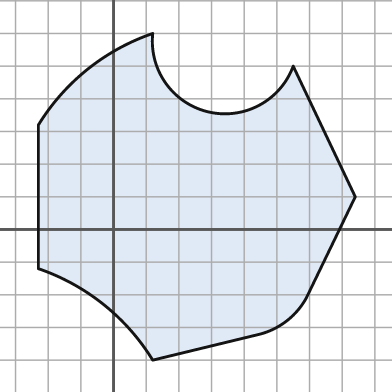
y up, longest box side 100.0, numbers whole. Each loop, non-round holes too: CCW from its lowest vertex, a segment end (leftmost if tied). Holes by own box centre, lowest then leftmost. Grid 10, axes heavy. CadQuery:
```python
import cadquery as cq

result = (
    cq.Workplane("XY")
    .moveTo(12.0, -40.0)
    .lineTo(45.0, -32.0)
    .threePointArc((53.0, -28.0), (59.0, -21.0))
    .lineTo(74.0, 10.0)
    .lineTo(55.0, 50.0)
    .threePointArc((29.0, 36.0), (12.0, 60.0))
    .threePointArc((-8.0, 49.0), (-23.0, 32.0))
    .lineTo(-23.0, -12.0)
    .threePointArc((-3.0, -23.0), (12.0, -40.0))
    .close()
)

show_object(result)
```